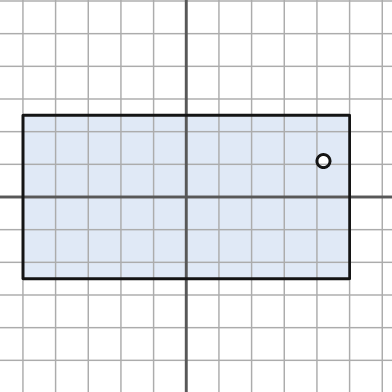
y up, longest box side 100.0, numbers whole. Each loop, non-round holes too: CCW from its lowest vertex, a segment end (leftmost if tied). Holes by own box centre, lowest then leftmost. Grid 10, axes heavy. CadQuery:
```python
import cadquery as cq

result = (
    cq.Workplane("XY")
    .moveTo(-50.0, -25.0)
    .lineTo(50.0, -25.0)
    .lineTo(50.0, 25.0)
    .lineTo(-50.0, 25.0)
    .close()
    .moveTo(42.0, 11.0)
    .circle(2.0)
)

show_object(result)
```